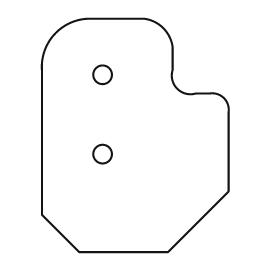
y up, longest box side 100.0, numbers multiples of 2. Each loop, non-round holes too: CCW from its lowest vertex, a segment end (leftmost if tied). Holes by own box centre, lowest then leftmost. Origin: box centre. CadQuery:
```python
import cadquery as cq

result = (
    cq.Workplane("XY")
    .moveTo(-24.0, -50.0)
    .lineTo(14.0, -50.0)
    .lineTo(40.0, -24.0)
    .lineTo(40.0, 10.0)
    .threePointArc((38.0, 16.0), (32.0, 18.0))
    .lineTo(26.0, 18.0)
    .threePointArc((18.0, 20.0), (16.0, 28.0))
    .lineTo(16.0, 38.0)
    .threePointArc((12.0, 46.0), (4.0, 50.0))
    .lineTo(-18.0, 50.0)
    .threePointArc((-34.0, 44.0), (-40.0, 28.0))
    .lineTo(-40.0, -34.0)
    .close()
    .moveTo(-14.0, -8.0)
    .circle(4.0)
    .moveTo(-14.0, 26.0)
    .circle(4.0)
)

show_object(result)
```